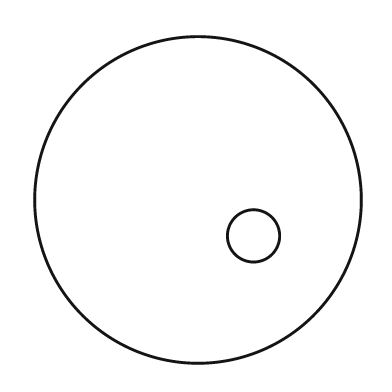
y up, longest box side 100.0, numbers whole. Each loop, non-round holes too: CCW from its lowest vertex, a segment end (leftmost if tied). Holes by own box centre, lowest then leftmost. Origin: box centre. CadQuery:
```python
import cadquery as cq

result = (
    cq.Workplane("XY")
    .moveTo(0.0, 0.0)
    .circle(50.0)
    .moveTo(17.0, -11.0)
    .circle(8.0)
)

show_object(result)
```